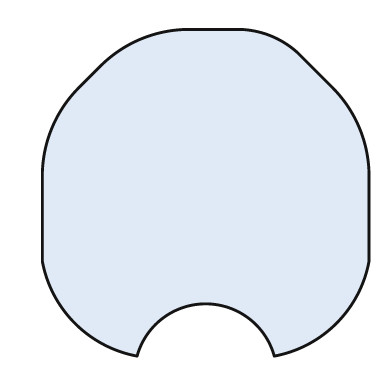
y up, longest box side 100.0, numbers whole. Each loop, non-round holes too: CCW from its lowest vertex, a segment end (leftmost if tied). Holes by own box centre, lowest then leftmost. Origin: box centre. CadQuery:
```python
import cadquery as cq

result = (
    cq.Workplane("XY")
    .moveTo(-21.0, -50.0)
    .threePointArc((0.0, -34.0), (21.0, -50.0))
    .threePointArc((40.0, -40.0), (50.0, -21.0))
    .lineTo(50.0, 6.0)
    .threePointArc((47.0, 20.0), (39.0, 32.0))
    .lineTo(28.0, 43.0)
    .threePointArc((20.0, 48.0), (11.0, 50.0))
    .lineTo(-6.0, 50.0)
    .threePointArc((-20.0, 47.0), (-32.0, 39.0))
    .lineTo(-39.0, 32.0)
    .threePointArc((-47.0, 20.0), (-50.0, 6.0))
    .lineTo(-50.0, -21.0)
    .threePointArc((-40.0, -40.0), (-21.0, -50.0))
    .close()
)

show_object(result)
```